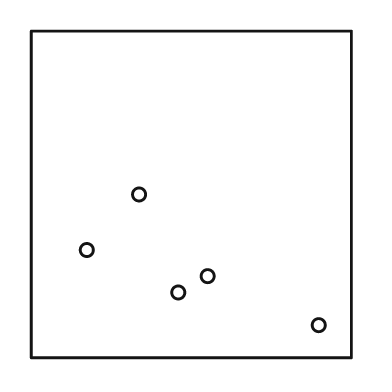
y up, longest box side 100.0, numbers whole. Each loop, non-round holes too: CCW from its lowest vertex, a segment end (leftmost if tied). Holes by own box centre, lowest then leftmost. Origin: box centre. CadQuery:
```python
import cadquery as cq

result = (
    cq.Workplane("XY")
    .moveTo(-49.0, -50.0)
    .lineTo(49.0, -50.0)
    .lineTo(49.0, 50.0)
    .lineTo(-49.0, 50.0)
    .close()
    .moveTo(39.0, -40.0)
    .circle(2.0)
    .moveTo(-4.0, -30.0)
    .circle(2.0)
    .moveTo(5.0, -25.0)
    .circle(2.0)
    .moveTo(-32.0, -17.0)
    .circle(2.0)
    .moveTo(-16.0, 0.0)
    .circle(2.0)
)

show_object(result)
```